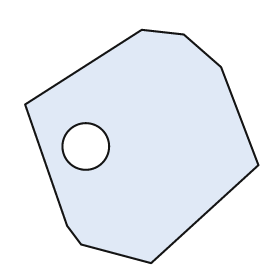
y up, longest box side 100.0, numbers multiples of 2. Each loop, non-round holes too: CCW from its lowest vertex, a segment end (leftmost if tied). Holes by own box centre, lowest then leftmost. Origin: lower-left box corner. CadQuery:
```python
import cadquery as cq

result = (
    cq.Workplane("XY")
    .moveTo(54.0, 0.0)
    .lineTo(100.0, 42.0)
    .lineTo(84.0, 84.0)
    .lineTo(68.0, 98.0)
    .lineTo(50.0, 100.0)
    .lineTo(0.0, 68.0)
    .lineTo(18.0, 16.0)
    .lineTo(24.0, 8.0)
    .close()
    .moveTo(26.0, 50.0)
    .circle(10.0)
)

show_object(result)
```